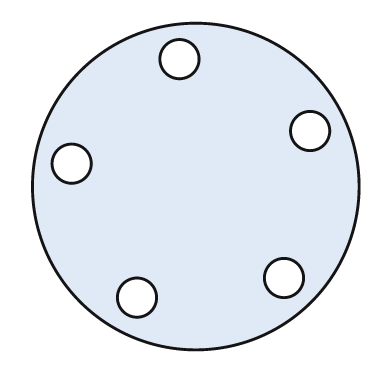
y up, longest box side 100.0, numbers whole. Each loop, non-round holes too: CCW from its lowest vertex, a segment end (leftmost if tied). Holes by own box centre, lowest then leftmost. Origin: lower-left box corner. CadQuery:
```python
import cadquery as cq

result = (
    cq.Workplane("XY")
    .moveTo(50.0, 50.0)
    .circle(50.0)
    .moveTo(32.0, 16.0)
    .circle(6.0)
    .moveTo(77.0, 22.0)
    .circle(6.0)
    .moveTo(12.0, 57.0)
    .circle(6.0)
    .moveTo(85.0, 67.0)
    .circle(6.0)
    .moveTo(45.0, 89.0)
    .circle(6.0)
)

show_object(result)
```